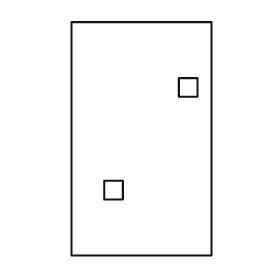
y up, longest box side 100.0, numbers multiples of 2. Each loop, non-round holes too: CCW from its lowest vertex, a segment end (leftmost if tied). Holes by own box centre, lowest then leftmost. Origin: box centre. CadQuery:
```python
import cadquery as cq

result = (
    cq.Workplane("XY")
    .moveTo(-30.0, -50.0)
    .lineTo(30.0, -50.0)
    .lineTo(30.0, 50.0)
    .lineTo(-30.0, 50.0)
    .close()
    .moveTo(-16.0, -26.0)
    .lineTo(-8.0, -26.0)
    .lineTo(-8.0, -18.0)
    .lineTo(-16.0, -18.0)
    .close()
    .moveTo(16.0, 18.0)
    .lineTo(24.0, 18.0)
    .lineTo(24.0, 26.0)
    .lineTo(16.0, 26.0)
    .close()
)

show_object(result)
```